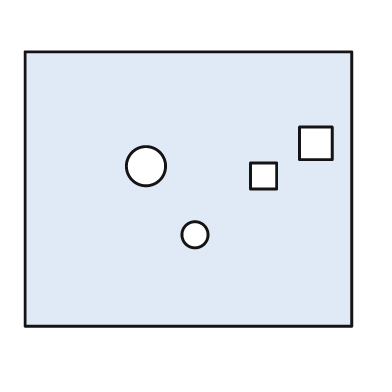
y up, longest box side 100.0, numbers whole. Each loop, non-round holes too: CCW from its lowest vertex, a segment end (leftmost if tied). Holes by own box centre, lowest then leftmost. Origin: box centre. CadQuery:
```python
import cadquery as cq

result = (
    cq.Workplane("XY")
    .moveTo(-50.0, -42.0)
    .lineTo(50.0, -42.0)
    .lineTo(50.0, 42.0)
    .lineTo(-50.0, 42.0)
    .close()
    .moveTo(2.0, -14.0)
    .circle(4.0)
    .moveTo(19.0, 0.0)
    .lineTo(27.0, 0.0)
    .lineTo(27.0, 8.0)
    .lineTo(19.0, 8.0)
    .close()
    .moveTo(-13.0, 7.0)
    .circle(6.0)
    .moveTo(34.0, 9.0)
    .lineTo(44.0, 9.0)
    .lineTo(44.0, 19.0)
    .lineTo(34.0, 19.0)
    .close()
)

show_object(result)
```